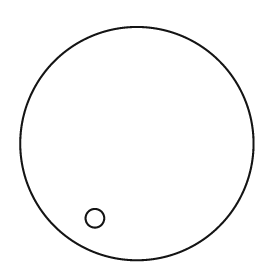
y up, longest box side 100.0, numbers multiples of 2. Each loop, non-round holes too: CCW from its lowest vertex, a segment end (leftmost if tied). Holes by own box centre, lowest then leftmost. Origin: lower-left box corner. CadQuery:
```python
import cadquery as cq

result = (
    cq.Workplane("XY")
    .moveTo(50.0, 50.0)
    .circle(50.0)
    .moveTo(32.0, 18.0)
    .circle(4.0)
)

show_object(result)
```